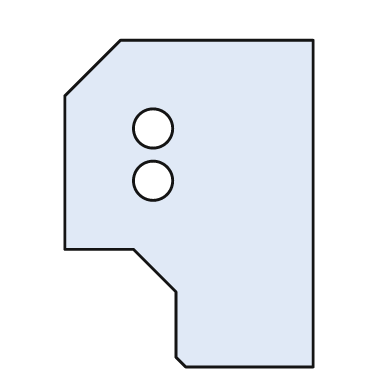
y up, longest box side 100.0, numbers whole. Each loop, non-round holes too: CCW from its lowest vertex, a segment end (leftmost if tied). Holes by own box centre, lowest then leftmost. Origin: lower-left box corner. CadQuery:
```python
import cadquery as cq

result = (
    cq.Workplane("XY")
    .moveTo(37.0, 0.0)
    .lineTo(76.0, 0.0)
    .lineTo(76.0, 100.0)
    .lineTo(17.0, 100.0)
    .lineTo(0.0, 83.0)
    .lineTo(0.0, 36.0)
    .lineTo(21.0, 36.0)
    .lineTo(34.0, 23.0)
    .lineTo(34.0, 3.0)
    .close()
    .moveTo(27.0, 57.0)
    .circle(6.0)
    .moveTo(27.0, 73.0)
    .circle(6.0)
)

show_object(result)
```